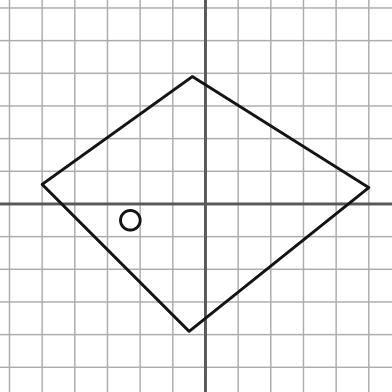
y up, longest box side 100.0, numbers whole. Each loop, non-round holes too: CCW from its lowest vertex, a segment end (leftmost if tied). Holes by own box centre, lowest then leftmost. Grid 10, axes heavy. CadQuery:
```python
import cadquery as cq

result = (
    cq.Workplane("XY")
    .moveTo(-5.0, -39.0)
    .lineTo(50.0, 5.0)
    .lineTo(-4.0, 39.0)
    .lineTo(-50.0, 6.0)
    .close()
    .moveTo(-23.0, -5.0)
    .circle(3.0)
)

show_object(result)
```